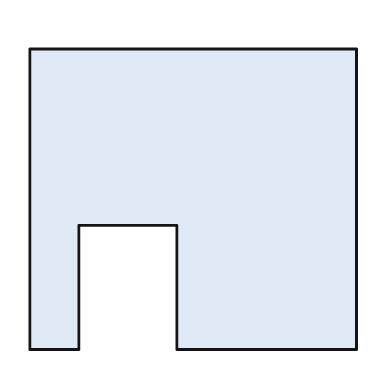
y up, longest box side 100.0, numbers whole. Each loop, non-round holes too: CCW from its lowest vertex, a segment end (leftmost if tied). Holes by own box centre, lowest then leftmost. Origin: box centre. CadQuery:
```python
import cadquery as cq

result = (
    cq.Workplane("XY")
    .moveTo(-50.0, -46.0)
    .lineTo(-35.0, -46.0)
    .lineTo(-35.0, -8.0)
    .lineTo(-5.0, -8.0)
    .lineTo(-5.0, -46.0)
    .lineTo(50.0, -46.0)
    .lineTo(50.0, 46.0)
    .lineTo(-50.0, 46.0)
    .close()
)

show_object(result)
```